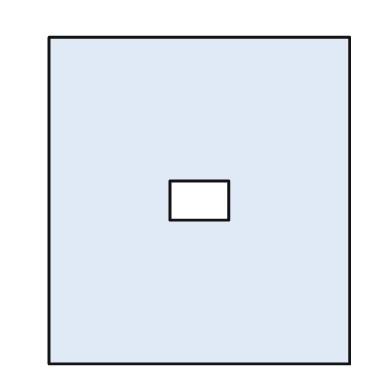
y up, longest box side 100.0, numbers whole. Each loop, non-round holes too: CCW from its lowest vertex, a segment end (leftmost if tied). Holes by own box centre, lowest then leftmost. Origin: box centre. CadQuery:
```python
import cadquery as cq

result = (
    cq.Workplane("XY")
    .moveTo(-46.0, -50.0)
    .lineTo(46.0, -50.0)
    .lineTo(46.0, 50.0)
    .lineTo(-46.0, 50.0)
    .close()
    .moveTo(-9.0, -6.0)
    .lineTo(9.0, -6.0)
    .lineTo(9.0, 6.0)
    .lineTo(-9.0, 6.0)
    .close()
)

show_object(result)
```